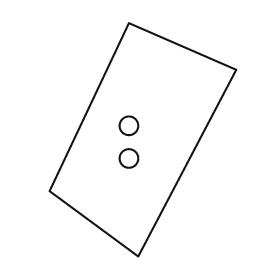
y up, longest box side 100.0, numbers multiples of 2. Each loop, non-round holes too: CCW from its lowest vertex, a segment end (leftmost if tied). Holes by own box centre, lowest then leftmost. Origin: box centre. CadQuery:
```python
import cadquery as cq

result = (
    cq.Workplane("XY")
    .moveTo(-2.0, -50.0)
    .lineTo(40.0, 30.0)
    .lineTo(-6.0, 50.0)
    .lineTo(-40.0, -22.0)
    .close()
    .moveTo(-6.0, -8.0)
    .circle(4.0)
    .moveTo(-6.0, 6.0)
    .circle(4.0)
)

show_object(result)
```